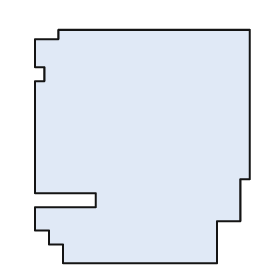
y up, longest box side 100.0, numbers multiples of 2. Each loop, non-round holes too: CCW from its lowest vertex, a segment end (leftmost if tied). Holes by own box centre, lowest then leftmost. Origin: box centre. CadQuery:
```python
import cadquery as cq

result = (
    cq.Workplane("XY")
    .moveTo(-34.0, -50.0)
    .lineTo(32.0, -50.0)
    .lineTo(32.0, -32.0)
    .lineTo(42.0, -32.0)
    .lineTo(42.0, -14.0)
    .lineTo(46.0, -14.0)
    .lineTo(46.0, 50.0)
    .lineTo(-36.0, 50.0)
    .lineTo(-36.0, 46.0)
    .lineTo(-46.0, 46.0)
    .lineTo(-46.0, 34.0)
    .lineTo(-42.0, 34.0)
    .lineTo(-42.0, 28.0)
    .lineTo(-46.0, 28.0)
    .lineTo(-46.0, -20.0)
    .lineTo(-20.0, -20.0)
    .lineTo(-20.0, -26.0)
    .lineTo(-46.0, -26.0)
    .lineTo(-46.0, -36.0)
    .lineTo(-40.0, -36.0)
    .lineTo(-40.0, -42.0)
    .lineTo(-34.0, -42.0)
    .close()
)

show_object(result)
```